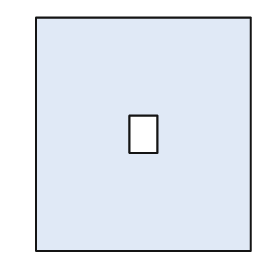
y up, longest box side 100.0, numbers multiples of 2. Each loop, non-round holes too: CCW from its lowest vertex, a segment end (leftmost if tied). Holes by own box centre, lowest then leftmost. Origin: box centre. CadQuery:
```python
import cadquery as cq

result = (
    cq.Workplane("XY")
    .moveTo(-46.0, -50.0)
    .lineTo(46.0, -50.0)
    .lineTo(46.0, 50.0)
    .lineTo(-46.0, 50.0)
    .close()
    .moveTo(-6.0, -8.0)
    .lineTo(6.0, -8.0)
    .lineTo(6.0, 8.0)
    .lineTo(-6.0, 8.0)
    .close()
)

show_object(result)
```